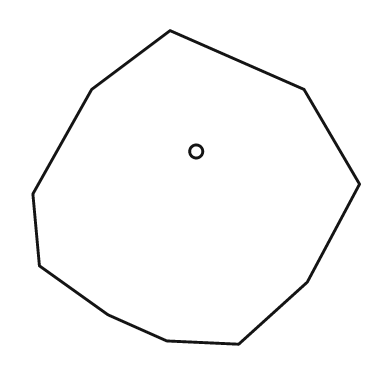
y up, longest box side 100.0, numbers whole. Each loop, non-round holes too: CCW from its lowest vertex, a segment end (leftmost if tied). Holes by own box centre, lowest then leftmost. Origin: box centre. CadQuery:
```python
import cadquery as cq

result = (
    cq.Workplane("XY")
    .moveTo(13.0, -48.0)
    .lineTo(34.0, -29.0)
    .lineTo(50.0, 1.0)
    .lineTo(33.0, 30.0)
    .lineTo(-8.0, 48.0)
    .lineTo(-32.0, 30.0)
    .lineTo(-50.0, -2.0)
    .lineTo(-48.0, -24.0)
    .lineTo(-27.0, -39.0)
    .lineTo(-9.0, -47.0)
    .close()
    .moveTo(0.0, 11.0)
    .circle(2.0)
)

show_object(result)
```